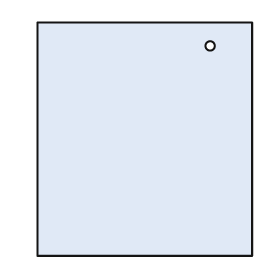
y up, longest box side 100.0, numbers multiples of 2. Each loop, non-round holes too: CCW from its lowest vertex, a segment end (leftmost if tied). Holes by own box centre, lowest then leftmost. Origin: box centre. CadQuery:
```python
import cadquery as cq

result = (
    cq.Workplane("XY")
    .moveTo(-46.0, -50.0)
    .lineTo(46.0, -50.0)
    .lineTo(46.0, 50.0)
    .lineTo(-46.0, 50.0)
    .close()
    .moveTo(28.0, 40.0)
    .circle(2.0)
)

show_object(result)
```